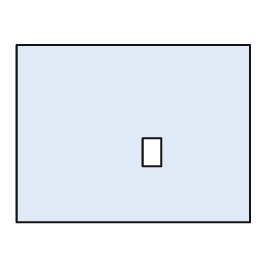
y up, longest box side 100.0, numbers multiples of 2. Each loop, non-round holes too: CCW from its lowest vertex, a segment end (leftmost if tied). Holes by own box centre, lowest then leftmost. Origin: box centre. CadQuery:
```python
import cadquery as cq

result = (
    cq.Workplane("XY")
    .moveTo(-50.0, -38.0)
    .lineTo(50.0, -38.0)
    .lineTo(50.0, 38.0)
    .lineTo(-50.0, 38.0)
    .close()
    .moveTo(4.0, -14.0)
    .lineTo(12.0, -14.0)
    .lineTo(12.0, -2.0)
    .lineTo(4.0, -2.0)
    .close()
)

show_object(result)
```